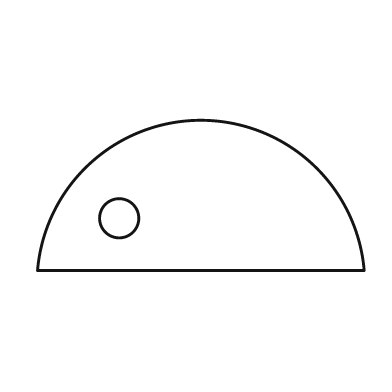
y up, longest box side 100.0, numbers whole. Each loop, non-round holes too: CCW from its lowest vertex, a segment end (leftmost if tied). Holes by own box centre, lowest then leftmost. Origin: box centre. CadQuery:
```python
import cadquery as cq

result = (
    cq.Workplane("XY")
    .moveTo(-50.0, -23.0)
    .lineTo(50.0, -23.0)
    .threePointArc((0.0, 23.0), (-50.0, -23.0))
    .close()
    .moveTo(-25.0, -7.0)
    .circle(6.0)
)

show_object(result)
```